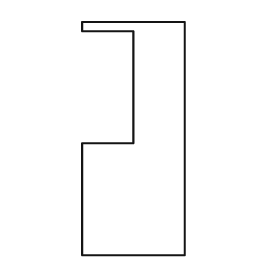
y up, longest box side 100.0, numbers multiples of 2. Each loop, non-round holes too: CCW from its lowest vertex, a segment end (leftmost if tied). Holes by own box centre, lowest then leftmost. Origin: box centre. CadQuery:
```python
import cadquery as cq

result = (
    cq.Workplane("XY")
    .moveTo(-22.0, -50.0)
    .lineTo(22.0, -50.0)
    .lineTo(22.0, 50.0)
    .lineTo(-22.0, 50.0)
    .lineTo(-22.0, 46.0)
    .lineTo(0.0, 46.0)
    .lineTo(0.0, -2.0)
    .lineTo(-22.0, -2.0)
    .close()
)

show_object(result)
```